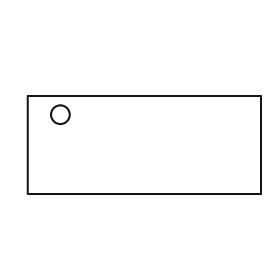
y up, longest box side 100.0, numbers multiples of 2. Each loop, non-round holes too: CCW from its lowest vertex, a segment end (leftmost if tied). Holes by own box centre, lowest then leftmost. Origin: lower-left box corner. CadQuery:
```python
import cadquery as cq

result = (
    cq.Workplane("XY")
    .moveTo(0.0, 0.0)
    .lineTo(100.0, 0.0)
    .lineTo(100.0, 42.0)
    .lineTo(0.0, 42.0)
    .close()
    .moveTo(14.0, 34.0)
    .circle(4.0)
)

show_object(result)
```